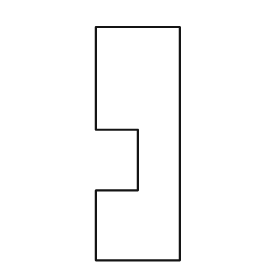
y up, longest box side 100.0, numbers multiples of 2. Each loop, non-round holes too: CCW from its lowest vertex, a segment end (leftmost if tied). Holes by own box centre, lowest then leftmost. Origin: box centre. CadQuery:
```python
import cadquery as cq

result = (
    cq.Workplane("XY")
    .moveTo(-18.0, -50.0)
    .lineTo(18.0, -50.0)
    .lineTo(18.0, 50.0)
    .lineTo(-18.0, 50.0)
    .lineTo(-18.0, 6.0)
    .lineTo(0.0, 6.0)
    .lineTo(0.0, -20.0)
    .lineTo(-18.0, -20.0)
    .close()
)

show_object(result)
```